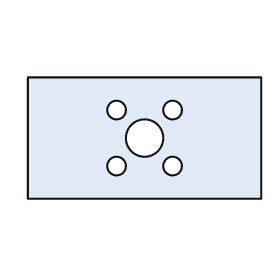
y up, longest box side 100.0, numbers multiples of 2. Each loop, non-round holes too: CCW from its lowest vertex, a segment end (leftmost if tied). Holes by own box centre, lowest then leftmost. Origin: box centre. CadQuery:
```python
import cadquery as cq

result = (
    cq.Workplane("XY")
    .moveTo(-50.0, -26.0)
    .lineTo(50.0, -26.0)
    .lineTo(50.0, 26.0)
    .lineTo(-50.0, 26.0)
    .close()
    .moveTo(-12.0, -12.0)
    .circle(4.0)
    .moveTo(12.0, -12.0)
    .circle(4.0)
    .moveTo(0.0, 0.0)
    .circle(8.0)
    .moveTo(-12.0, 12.0)
    .circle(4.0)
    .moveTo(12.0, 12.0)
    .circle(4.0)
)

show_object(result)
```